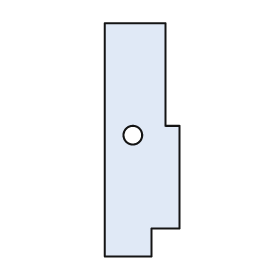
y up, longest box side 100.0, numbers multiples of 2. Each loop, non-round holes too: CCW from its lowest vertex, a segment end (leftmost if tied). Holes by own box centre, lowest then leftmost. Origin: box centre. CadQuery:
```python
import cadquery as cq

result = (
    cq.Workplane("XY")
    .moveTo(-16.0, -50.0)
    .lineTo(4.0, -50.0)
    .lineTo(4.0, -38.0)
    .lineTo(16.0, -38.0)
    .lineTo(16.0, 6.0)
    .lineTo(10.0, 6.0)
    .lineTo(10.0, 50.0)
    .lineTo(-16.0, 50.0)
    .close()
    .moveTo(-4.0, 2.0)
    .circle(4.0)
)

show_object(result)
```